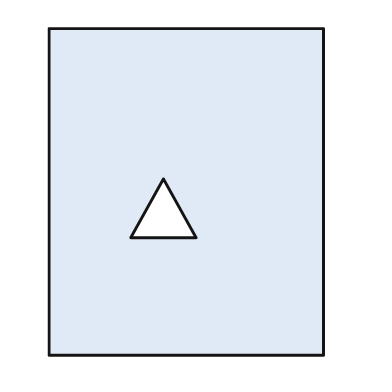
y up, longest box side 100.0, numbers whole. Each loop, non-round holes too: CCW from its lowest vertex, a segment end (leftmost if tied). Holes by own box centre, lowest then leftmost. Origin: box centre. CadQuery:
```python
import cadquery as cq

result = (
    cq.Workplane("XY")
    .moveTo(-42.0, -50.0)
    .lineTo(42.0, -50.0)
    .lineTo(42.0, 50.0)
    .lineTo(-42.0, 50.0)
    .close()
    .moveTo(-17.0, -14.0)
    .lineTo(3.0, -14.0)
    .lineTo(-7.0, 4.0)
    .close()
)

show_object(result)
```